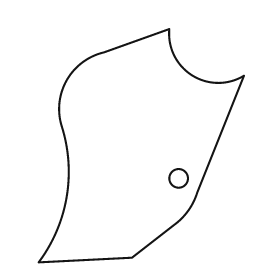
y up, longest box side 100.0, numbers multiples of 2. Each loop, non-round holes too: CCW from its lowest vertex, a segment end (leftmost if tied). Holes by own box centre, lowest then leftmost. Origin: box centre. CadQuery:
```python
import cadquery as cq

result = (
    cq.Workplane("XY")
    .moveTo(-44.0, -50.0)
    .lineTo(-4.0, -48.0)
    .lineTo(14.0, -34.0)
    .threePointArc((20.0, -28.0), (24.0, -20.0))
    .lineTo(44.0, 30.0)
    .threePointArc((22.0, 30.0), (12.0, 50.0))
    .lineTo(-16.0, 40.0)
    .threePointArc((-32.0, 28.0), (-34.0, 8.0))
    .threePointArc((-32.0, -22.0), (-44.0, -50.0))
    .close()
    .moveTo(16.0, -14.0)
    .circle(4.0)
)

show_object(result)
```